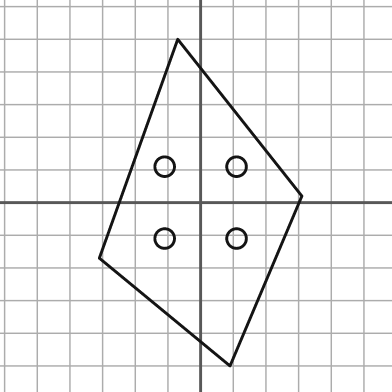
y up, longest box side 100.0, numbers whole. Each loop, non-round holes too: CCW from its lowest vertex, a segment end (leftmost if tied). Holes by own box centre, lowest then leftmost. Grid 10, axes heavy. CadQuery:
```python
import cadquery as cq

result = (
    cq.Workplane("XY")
    .moveTo(9.0, -50.0)
    .lineTo(31.0, 2.0)
    .lineTo(-7.0, 50.0)
    .lineTo(-31.0, -17.0)
    .close()
    .moveTo(-11.0, -11.0)
    .circle(3.0)
    .moveTo(11.0, -11.0)
    .circle(3.0)
    .moveTo(-11.0, 11.0)
    .circle(3.0)
    .moveTo(11.0, 11.0)
    .circle(3.0)
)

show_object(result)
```